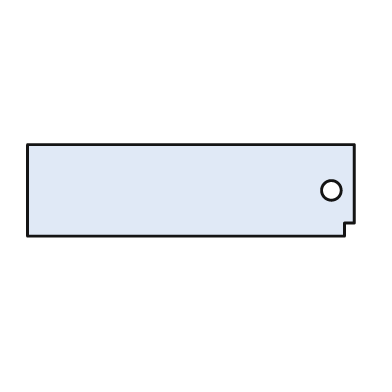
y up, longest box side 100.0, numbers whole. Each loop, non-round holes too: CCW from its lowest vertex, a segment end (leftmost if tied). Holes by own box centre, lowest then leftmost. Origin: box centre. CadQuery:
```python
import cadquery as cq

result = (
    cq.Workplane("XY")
    .moveTo(-50.0, -14.0)
    .lineTo(47.0, -14.0)
    .lineTo(47.0, -10.0)
    .lineTo(50.0, -10.0)
    .lineTo(50.0, 14.0)
    .lineTo(-50.0, 14.0)
    .close()
    .moveTo(43.0, 0.0)
    .circle(3.0)
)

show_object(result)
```